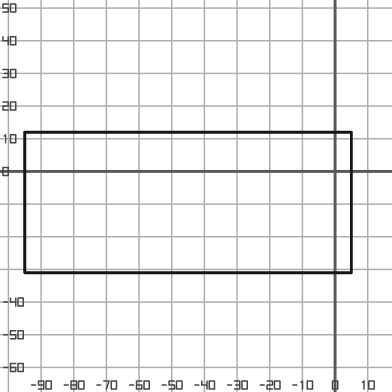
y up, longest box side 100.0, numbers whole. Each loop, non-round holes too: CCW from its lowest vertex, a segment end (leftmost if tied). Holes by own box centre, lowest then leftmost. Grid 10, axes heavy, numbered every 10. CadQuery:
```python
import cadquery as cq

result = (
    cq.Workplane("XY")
    .moveTo(-95.0, -31.0)
    .lineTo(5.0, -31.0)
    .lineTo(5.0, 12.0)
    .lineTo(-95.0, 12.0)
    .close()
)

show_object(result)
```